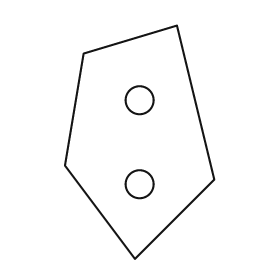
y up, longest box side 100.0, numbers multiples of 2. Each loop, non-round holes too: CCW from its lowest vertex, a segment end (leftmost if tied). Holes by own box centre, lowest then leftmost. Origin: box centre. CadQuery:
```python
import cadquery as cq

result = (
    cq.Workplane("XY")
    .moveTo(-2.0, -50.0)
    .lineTo(32.0, -16.0)
    .lineTo(16.0, 50.0)
    .lineTo(-24.0, 38.0)
    .lineTo(-32.0, -10.0)
    .close()
    .moveTo(0.0, -18.0)
    .circle(6.0)
    .moveTo(0.0, 18.0)
    .circle(6.0)
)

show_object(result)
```